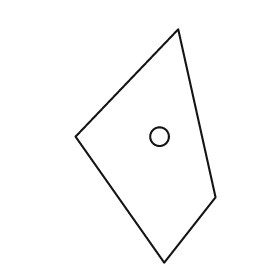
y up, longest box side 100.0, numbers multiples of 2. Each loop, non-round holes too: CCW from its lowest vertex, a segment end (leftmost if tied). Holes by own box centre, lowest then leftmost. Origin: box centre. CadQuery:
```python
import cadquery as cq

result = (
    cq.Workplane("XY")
    .moveTo(8.0, -50.0)
    .lineTo(30.0, -22.0)
    .lineTo(14.0, 50.0)
    .lineTo(-30.0, 4.0)
    .close()
    .moveTo(6.0, 4.0)
    .circle(4.0)
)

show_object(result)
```